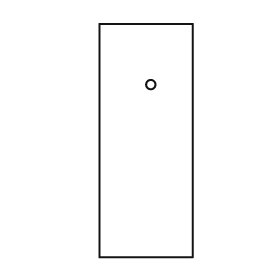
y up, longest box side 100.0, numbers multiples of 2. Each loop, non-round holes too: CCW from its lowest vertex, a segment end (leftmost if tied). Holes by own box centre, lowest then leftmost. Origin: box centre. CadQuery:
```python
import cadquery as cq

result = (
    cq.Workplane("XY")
    .moveTo(-20.0, -50.0)
    .lineTo(20.0, -50.0)
    .lineTo(20.0, 50.0)
    .lineTo(-20.0, 50.0)
    .close()
    .moveTo(2.0, 24.0)
    .circle(2.0)
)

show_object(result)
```